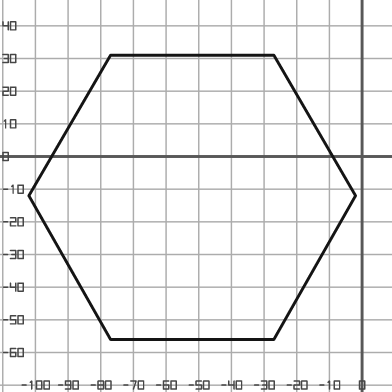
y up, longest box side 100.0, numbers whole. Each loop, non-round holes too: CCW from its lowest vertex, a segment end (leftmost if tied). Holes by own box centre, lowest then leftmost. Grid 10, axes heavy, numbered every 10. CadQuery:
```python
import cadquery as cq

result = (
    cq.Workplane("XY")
    .moveTo(-77.0, -56.0)
    .lineTo(-27.0, -56.0)
    .lineTo(-2.0, -12.0)
    .lineTo(-27.0, 31.0)
    .lineTo(-77.0, 31.0)
    .lineTo(-102.0, -12.0)
    .close()
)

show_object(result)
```